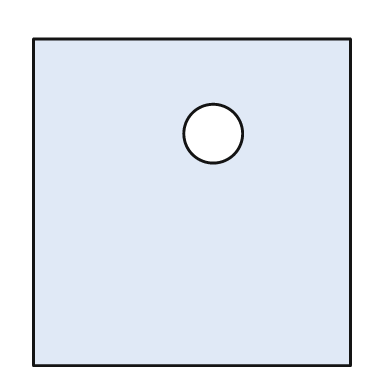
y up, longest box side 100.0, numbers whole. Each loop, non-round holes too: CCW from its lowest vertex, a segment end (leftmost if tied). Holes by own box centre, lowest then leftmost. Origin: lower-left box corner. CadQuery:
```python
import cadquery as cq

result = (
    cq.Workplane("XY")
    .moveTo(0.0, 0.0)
    .lineTo(97.0, 0.0)
    .lineTo(97.0, 100.0)
    .lineTo(0.0, 100.0)
    .close()
    .moveTo(55.0, 71.0)
    .circle(9.0)
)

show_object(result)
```